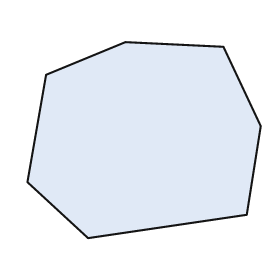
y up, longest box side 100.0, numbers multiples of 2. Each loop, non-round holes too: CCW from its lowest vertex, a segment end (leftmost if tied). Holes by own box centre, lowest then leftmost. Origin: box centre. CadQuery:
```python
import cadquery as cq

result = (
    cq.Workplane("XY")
    .moveTo(-24.0, -42.0)
    .lineTo(44.0, -32.0)
    .lineTo(50.0, 6.0)
    .lineTo(34.0, 40.0)
    .lineTo(-8.0, 42.0)
    .lineTo(-42.0, 28.0)
    .lineTo(-50.0, -18.0)
    .close()
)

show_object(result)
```